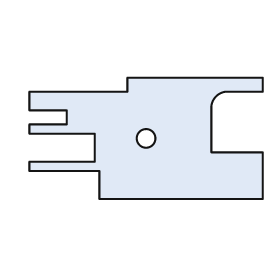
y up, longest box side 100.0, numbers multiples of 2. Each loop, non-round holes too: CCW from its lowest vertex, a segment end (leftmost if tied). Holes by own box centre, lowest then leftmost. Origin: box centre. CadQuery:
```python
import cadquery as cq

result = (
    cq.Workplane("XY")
    .moveTo(-20.0, -26.0)
    .lineTo(50.0, -26.0)
    .lineTo(50.0, -6.0)
    .lineTo(28.0, -6.0)
    .lineTo(28.0, 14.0)
    .threePointArc((30.0, 18.0), (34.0, 20.0))
    .lineTo(50.0, 20.0)
    .lineTo(50.0, 26.0)
    .lineTo(-8.0, 26.0)
    .lineTo(-8.0, 20.0)
    .lineTo(-50.0, 20.0)
    .lineTo(-50.0, 12.0)
    .lineTo(-34.0, 12.0)
    .lineTo(-34.0, 6.0)
    .lineTo(-50.0, 6.0)
    .lineTo(-50.0, 2.0)
    .lineTo(-22.0, 2.0)
    .lineTo(-22.0, -10.0)
    .lineTo(-50.0, -10.0)
    .lineTo(-50.0, -14.0)
    .lineTo(-20.0, -14.0)
    .close()
    .moveTo(0.0, 0.0)
    .circle(4.0)
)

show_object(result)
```